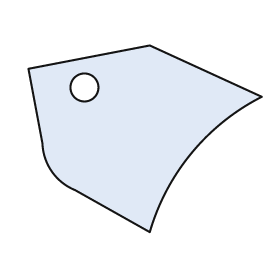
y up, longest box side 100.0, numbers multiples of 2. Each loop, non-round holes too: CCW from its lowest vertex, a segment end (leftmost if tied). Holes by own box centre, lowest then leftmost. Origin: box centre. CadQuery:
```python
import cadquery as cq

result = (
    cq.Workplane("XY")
    .moveTo(2.0, -40.0)
    .threePointArc((20.0, -6.0), (50.0, 18.0))
    .lineTo(2.0, 40.0)
    .lineTo(-50.0, 30.0)
    .lineTo(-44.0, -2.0)
    .threePointArc((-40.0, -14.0), (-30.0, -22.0))
    .close()
    .moveTo(-26.0, 22.0)
    .circle(6.0)
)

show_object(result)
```